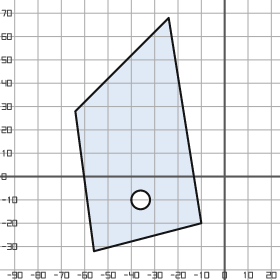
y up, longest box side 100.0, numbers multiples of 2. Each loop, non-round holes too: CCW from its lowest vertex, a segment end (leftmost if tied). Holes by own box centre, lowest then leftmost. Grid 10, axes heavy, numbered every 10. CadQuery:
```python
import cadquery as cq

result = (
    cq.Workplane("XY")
    .moveTo(-56.0, -32.0)
    .lineTo(-10.0, -20.0)
    .lineTo(-24.0, 68.0)
    .lineTo(-64.0, 28.0)
    .close()
    .moveTo(-36.0, -10.0)
    .circle(4.0)
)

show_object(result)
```